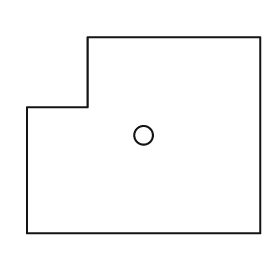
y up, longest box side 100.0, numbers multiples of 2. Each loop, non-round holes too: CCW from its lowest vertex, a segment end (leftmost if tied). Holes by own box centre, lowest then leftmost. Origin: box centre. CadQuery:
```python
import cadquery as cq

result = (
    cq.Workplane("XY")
    .moveTo(-50.0, -42.0)
    .lineTo(50.0, -42.0)
    .lineTo(50.0, 42.0)
    .lineTo(-24.0, 42.0)
    .lineTo(-24.0, 12.0)
    .lineTo(-50.0, 12.0)
    .close()
    .moveTo(0.0, 0.0)
    .circle(4.0)
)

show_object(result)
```